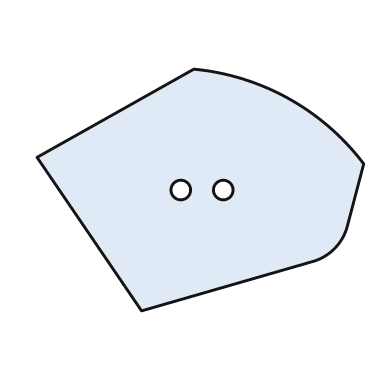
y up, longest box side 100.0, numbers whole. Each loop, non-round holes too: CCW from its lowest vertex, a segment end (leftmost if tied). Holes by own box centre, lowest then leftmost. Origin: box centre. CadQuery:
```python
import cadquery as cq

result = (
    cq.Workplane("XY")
    .moveTo(-18.0, -37.0)
    .lineTo(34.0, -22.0)
    .threePointArc((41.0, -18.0), (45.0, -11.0))
    .lineTo(50.0, 8.0)
    .threePointArc((27.0, 28.0), (-2.0, 37.0))
    .lineTo(-50.0, 10.0)
    .close()
    .moveTo(-6.0, 0.0)
    .circle(3.0)
    .moveTo(7.0, 0.0)
    .circle(3.0)
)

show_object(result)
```